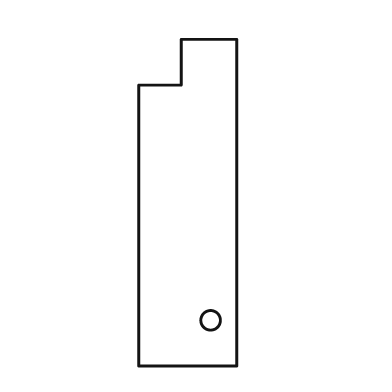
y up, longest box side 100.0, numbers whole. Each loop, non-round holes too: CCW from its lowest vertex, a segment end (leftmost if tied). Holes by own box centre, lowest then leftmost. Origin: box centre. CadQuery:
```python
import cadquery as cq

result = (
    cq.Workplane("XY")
    .moveTo(-15.0, -50.0)
    .lineTo(15.0, -50.0)
    .lineTo(15.0, 50.0)
    .lineTo(-2.0, 50.0)
    .lineTo(-2.0, 36.0)
    .lineTo(-15.0, 36.0)
    .close()
    .moveTo(7.0, -36.0)
    .circle(3.0)
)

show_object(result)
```